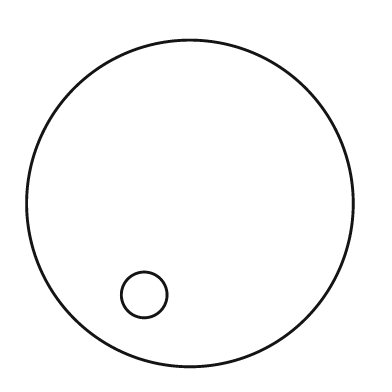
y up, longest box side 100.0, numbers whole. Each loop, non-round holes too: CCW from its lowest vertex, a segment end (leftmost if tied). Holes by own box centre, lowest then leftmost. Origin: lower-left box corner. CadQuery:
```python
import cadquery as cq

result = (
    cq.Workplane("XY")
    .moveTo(50.0, 50.0)
    .circle(50.0)
    .moveTo(36.0, 22.0)
    .circle(7.0)
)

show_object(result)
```